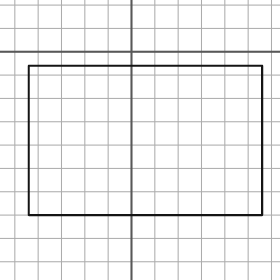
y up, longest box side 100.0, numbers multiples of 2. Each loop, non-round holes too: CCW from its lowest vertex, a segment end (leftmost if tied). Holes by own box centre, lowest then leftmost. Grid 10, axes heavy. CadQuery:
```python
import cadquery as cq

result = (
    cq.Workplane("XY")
    .moveTo(-44.0, -70.0)
    .lineTo(56.0, -70.0)
    .lineTo(56.0, -6.0)
    .lineTo(-44.0, -6.0)
    .close()
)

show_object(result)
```